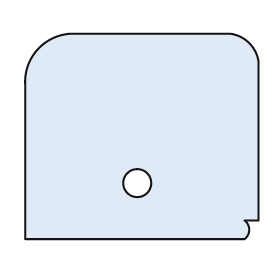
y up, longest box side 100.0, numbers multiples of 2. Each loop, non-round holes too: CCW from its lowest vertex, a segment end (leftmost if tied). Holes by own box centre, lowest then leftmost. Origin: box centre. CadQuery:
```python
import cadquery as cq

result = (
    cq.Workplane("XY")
    .moveTo(-50.0, -44.0)
    .lineTo(44.0, -44.0)
    .threePointArc((46.0, -40.0), (44.0, -36.0))
    .lineTo(50.0, -36.0)
    .lineTo(50.0, 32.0)
    .threePointArc((46.0, 40.0), (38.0, 44.0))
    .lineTo(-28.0, 44.0)
    .threePointArc((-44.0, 38.0), (-50.0, 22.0))
    .close()
    .moveTo(-2.0, -20.0)
    .circle(6.0)
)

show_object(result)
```